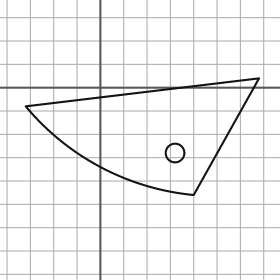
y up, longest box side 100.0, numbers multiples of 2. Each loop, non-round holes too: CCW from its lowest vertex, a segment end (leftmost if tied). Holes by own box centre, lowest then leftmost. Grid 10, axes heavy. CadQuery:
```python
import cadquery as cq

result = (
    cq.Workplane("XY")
    .moveTo(40.0, -46.0)
    .lineTo(68.0, 4.0)
    .lineTo(-32.0, -8.0)
    .threePointArc((0.0, -34.0), (40.0, -46.0))
    .close()
    .moveTo(32.0, -28.0)
    .circle(4.0)
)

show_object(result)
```